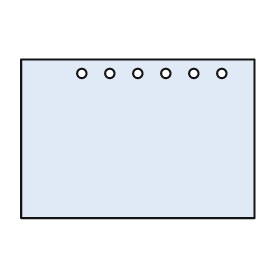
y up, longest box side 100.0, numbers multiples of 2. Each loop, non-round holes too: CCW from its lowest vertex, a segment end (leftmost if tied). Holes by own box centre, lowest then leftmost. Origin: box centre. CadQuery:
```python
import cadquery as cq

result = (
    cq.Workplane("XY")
    .moveTo(-50.0, -34.0)
    .lineTo(50.0, -34.0)
    .lineTo(50.0, 34.0)
    .lineTo(-50.0, 34.0)
    .close()
    .moveTo(-24.0, 28.0)
    .circle(2.0)
    .moveTo(-12.0, 28.0)
    .circle(2.0)
    .moveTo(0.0, 28.0)
    .circle(2.0)
    .moveTo(12.0, 28.0)
    .circle(2.0)
    .moveTo(24.0, 28.0)
    .circle(2.0)
    .moveTo(36.0, 28.0)
    .circle(2.0)
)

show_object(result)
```